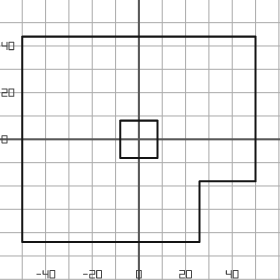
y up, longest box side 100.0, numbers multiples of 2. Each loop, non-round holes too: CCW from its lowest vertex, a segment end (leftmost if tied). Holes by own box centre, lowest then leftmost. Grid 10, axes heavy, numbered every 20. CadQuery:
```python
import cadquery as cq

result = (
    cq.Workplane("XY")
    .moveTo(-50.0, -44.0)
    .lineTo(26.0, -44.0)
    .lineTo(26.0, -18.0)
    .lineTo(50.0, -18.0)
    .lineTo(50.0, 44.0)
    .lineTo(-50.0, 44.0)
    .close()
    .moveTo(-8.0, -8.0)
    .lineTo(8.0, -8.0)
    .lineTo(8.0, 8.0)
    .lineTo(-8.0, 8.0)
    .close()
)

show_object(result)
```